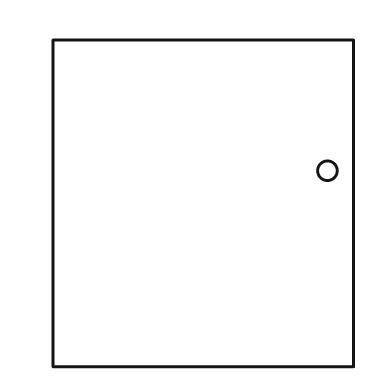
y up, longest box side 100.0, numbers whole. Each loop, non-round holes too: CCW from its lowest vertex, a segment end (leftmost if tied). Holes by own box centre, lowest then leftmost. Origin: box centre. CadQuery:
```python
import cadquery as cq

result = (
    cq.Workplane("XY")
    .moveTo(-46.0, -50.0)
    .lineTo(46.0, -50.0)
    .lineTo(46.0, 50.0)
    .lineTo(-46.0, 50.0)
    .close()
    .moveTo(38.0, 10.0)
    .circle(3.0)
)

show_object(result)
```